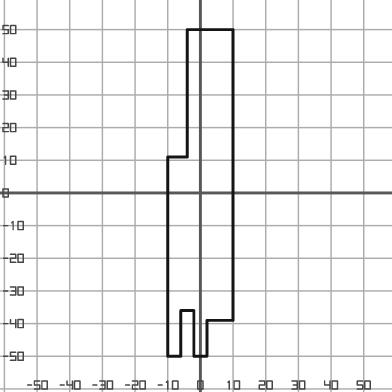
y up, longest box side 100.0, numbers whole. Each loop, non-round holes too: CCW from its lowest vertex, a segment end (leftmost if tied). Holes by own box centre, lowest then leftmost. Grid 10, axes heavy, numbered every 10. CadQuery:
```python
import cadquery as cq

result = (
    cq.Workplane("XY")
    .moveTo(-10.0, -50.0)
    .lineTo(-6.0, -50.0)
    .lineTo(-6.0, -36.0)
    .lineTo(-2.0, -36.0)
    .lineTo(-2.0, -50.0)
    .lineTo(2.0, -50.0)
    .lineTo(2.0, -39.0)
    .lineTo(10.0, -39.0)
    .lineTo(10.0, 50.0)
    .lineTo(-4.0, 50.0)
    .lineTo(-4.0, 11.0)
    .lineTo(-10.0, 11.0)
    .close()
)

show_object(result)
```